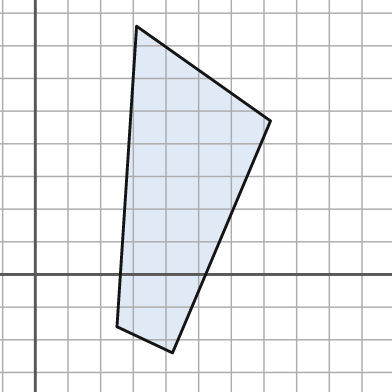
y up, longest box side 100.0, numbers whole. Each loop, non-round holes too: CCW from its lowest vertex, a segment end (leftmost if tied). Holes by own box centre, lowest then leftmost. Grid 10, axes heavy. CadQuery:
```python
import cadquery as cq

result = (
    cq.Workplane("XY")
    .moveTo(42.0, -24.0)
    .lineTo(72.0, 47.0)
    .lineTo(31.0, 76.0)
    .lineTo(25.0, -16.0)
    .close()
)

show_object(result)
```